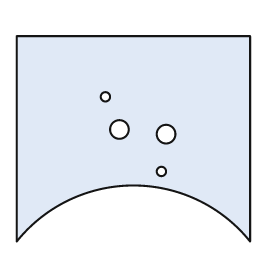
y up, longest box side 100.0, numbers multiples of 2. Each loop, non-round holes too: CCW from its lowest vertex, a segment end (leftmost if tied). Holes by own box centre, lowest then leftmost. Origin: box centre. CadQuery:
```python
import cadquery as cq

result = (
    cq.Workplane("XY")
    .moveTo(-50.0, -44.0)
    .threePointArc((0.0, -20.0), (50.0, -44.0))
    .lineTo(50.0, 44.0)
    .lineTo(-50.0, 44.0)
    .close()
    .moveTo(12.0, -14.0)
    .circle(2.0)
    .moveTo(14.0, 2.0)
    .circle(4.0)
    .moveTo(-6.0, 4.0)
    .circle(4.0)
    .moveTo(-12.0, 18.0)
    .circle(2.0)
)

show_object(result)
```